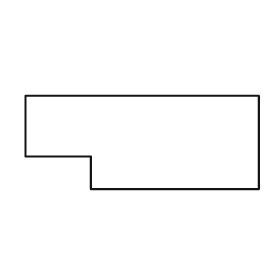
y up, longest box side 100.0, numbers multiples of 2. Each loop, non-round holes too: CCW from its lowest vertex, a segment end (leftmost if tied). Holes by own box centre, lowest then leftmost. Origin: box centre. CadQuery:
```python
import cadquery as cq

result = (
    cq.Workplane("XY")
    .moveTo(-22.0, -20.0)
    .lineTo(50.0, -20.0)
    .lineTo(50.0, 20.0)
    .lineTo(-50.0, 20.0)
    .lineTo(-50.0, -6.0)
    .lineTo(-22.0, -6.0)
    .close()
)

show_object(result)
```